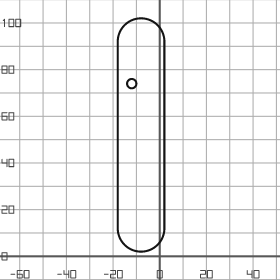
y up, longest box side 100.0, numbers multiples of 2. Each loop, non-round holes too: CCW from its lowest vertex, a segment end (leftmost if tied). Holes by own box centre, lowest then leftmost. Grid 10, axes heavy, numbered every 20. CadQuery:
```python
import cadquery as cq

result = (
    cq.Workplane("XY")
    .moveTo(-18.0, 12.0)
    .threePointArc((-8.0, 2.0), (2.0, 12.0))
    .lineTo(2.0, 92.0)
    .threePointArc((-8.0, 102.0), (-18.0, 92.0))
    .close()
    .moveTo(-12.0, 74.0)
    .circle(2.0)
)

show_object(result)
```